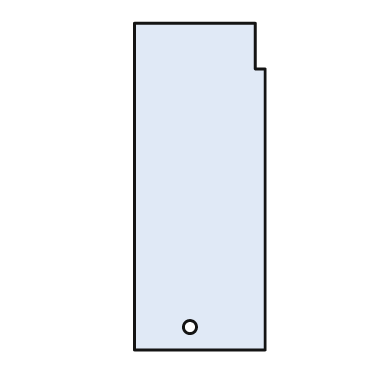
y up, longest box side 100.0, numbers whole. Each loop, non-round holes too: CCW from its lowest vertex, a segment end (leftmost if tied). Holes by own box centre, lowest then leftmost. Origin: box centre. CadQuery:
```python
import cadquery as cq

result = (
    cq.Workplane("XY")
    .moveTo(-20.0, -50.0)
    .lineTo(20.0, -50.0)
    .lineTo(20.0, 36.0)
    .lineTo(17.0, 36.0)
    .lineTo(17.0, 50.0)
    .lineTo(-20.0, 50.0)
    .close()
    .moveTo(-3.0, -43.0)
    .circle(2.0)
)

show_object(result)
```